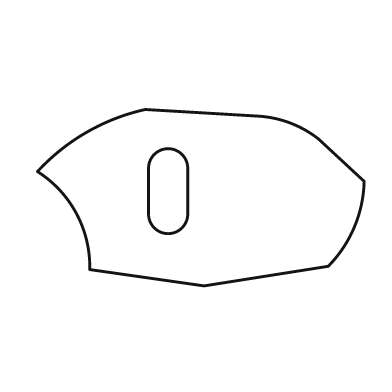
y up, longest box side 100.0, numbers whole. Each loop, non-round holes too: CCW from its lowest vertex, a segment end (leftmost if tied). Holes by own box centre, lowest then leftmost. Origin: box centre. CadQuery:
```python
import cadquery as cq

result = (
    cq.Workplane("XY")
    .moveTo(1.0, -27.0)
    .lineTo(39.0, -21.0)
    .threePointArc((47.0, -9.0), (50.0, 5.0))
    .lineTo(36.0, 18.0)
    .threePointArc((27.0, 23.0), (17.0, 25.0))
    .lineTo(-17.0, 27.0)
    .threePointArc((-35.0, 20.0), (-50.0, 8.0))
    .threePointArc((-38.0, -5.0), (-34.0, -22.0))
    .close()
    .moveTo(-16.0, -5.0)
    .threePointArc((-10.0, -11.0), (-4.0, -5.0))
    .lineTo(-4.0, 9.0)
    .threePointArc((-10.0, 15.0), (-16.0, 9.0))
    .close()
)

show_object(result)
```